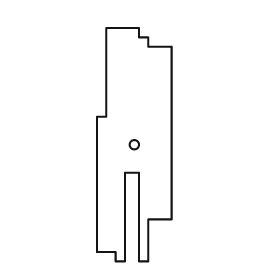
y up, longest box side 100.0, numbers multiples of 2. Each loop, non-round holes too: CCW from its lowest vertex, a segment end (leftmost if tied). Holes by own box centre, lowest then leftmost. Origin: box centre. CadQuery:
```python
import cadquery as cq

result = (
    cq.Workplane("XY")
    .moveTo(-8.0, -50.0)
    .lineTo(-4.0, -50.0)
    .lineTo(-4.0, -12.0)
    .lineTo(2.0, -12.0)
    .lineTo(2.0, -50.0)
    .lineTo(6.0, -50.0)
    .lineTo(6.0, -32.0)
    .lineTo(16.0, -32.0)
    .lineTo(16.0, 42.0)
    .lineTo(6.0, 42.0)
    .lineTo(6.0, 46.0)
    .lineTo(2.0, 46.0)
    .lineTo(2.0, 50.0)
    .lineTo(-12.0, 50.0)
    .lineTo(-12.0, 12.0)
    .lineTo(-16.0, 12.0)
    .lineTo(-16.0, -46.0)
    .lineTo(-8.0, -46.0)
    .close()
    .moveTo(0.0, 0.0)
    .circle(2.0)
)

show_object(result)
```